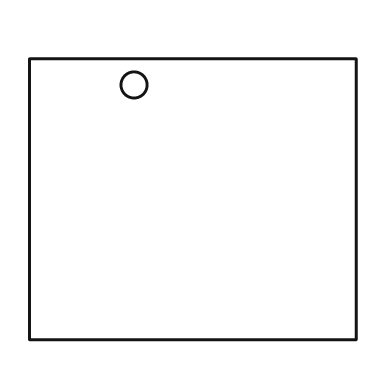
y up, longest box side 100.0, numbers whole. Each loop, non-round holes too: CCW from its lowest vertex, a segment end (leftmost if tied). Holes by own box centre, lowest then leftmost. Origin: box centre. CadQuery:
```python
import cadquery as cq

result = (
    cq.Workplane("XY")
    .moveTo(-50.0, -43.0)
    .lineTo(50.0, -43.0)
    .lineTo(50.0, 43.0)
    .lineTo(-50.0, 43.0)
    .close()
    .moveTo(-18.0, 35.0)
    .circle(4.0)
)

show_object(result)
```